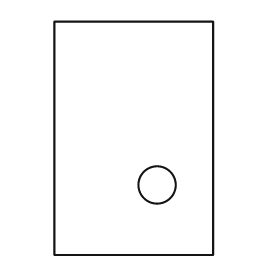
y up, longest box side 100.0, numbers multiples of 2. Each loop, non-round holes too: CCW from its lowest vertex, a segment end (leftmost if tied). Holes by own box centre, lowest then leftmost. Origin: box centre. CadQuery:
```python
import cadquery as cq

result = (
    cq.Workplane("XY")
    .moveTo(-34.0, -50.0)
    .lineTo(34.0, -50.0)
    .lineTo(34.0, 50.0)
    .lineTo(-34.0, 50.0)
    .close()
    .moveTo(10.0, -20.0)
    .circle(8.0)
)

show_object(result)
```